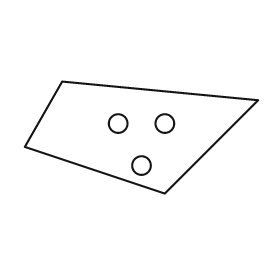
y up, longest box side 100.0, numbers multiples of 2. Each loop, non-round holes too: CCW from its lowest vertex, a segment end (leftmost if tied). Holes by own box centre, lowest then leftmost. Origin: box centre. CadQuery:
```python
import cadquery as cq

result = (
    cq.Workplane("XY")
    .moveTo(10.0, -24.0)
    .lineTo(50.0, 16.0)
    .lineTo(-34.0, 24.0)
    .lineTo(-50.0, -4.0)
    .close()
    .moveTo(0.0, -12.0)
    .circle(4.0)
    .moveTo(-10.0, 6.0)
    .circle(4.0)
    .moveTo(10.0, 6.0)
    .circle(4.0)
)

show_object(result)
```